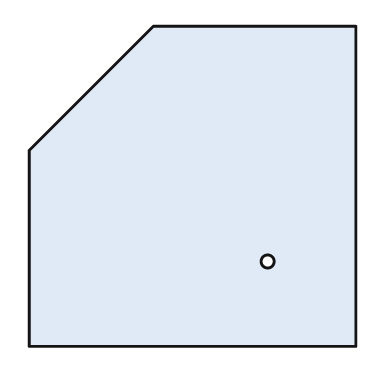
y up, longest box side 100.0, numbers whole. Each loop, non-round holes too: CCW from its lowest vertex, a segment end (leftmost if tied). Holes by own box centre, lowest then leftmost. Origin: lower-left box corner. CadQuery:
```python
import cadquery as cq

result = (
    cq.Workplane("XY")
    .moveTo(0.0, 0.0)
    .lineTo(100.0, 0.0)
    .lineTo(100.0, 98.0)
    .lineTo(38.0, 98.0)
    .lineTo(0.0, 60.0)
    .close()
    .moveTo(73.0, 26.0)
    .circle(2.0)
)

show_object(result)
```